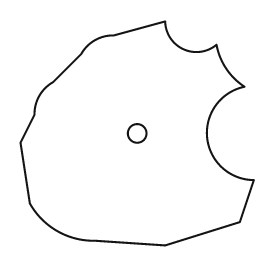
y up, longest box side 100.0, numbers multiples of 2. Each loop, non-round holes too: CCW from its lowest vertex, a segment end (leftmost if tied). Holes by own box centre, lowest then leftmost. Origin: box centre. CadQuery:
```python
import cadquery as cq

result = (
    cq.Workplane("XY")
    .moveTo(12.0, -48.0)
    .lineTo(44.0, -38.0)
    .lineTo(50.0, -20.0)
    .threePointArc((30.0, -2.0), (46.0, 20.0))
    .threePointArc((38.0, 28.0), (34.0, 38.0))
    .threePointArc((20.0, 36.0), (12.0, 48.0))
    .lineTo(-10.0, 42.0)
    .threePointArc((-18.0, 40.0), (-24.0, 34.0))
    .lineTo(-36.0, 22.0)
    .threePointArc((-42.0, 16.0), (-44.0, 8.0))
    .lineTo(-50.0, -4.0)
    .lineTo(-46.0, -30.0)
    .threePointArc((-34.0, -42.0), (-18.0, -46.0))
    .close()
    .moveTo(0.0, 0.0)
    .circle(4.0)
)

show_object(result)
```